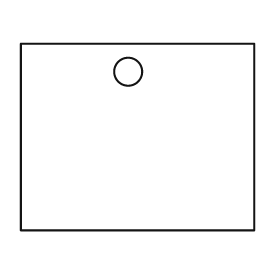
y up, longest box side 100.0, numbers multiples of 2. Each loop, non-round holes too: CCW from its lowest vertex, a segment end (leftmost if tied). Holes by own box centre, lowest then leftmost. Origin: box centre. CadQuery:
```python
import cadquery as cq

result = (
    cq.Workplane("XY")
    .moveTo(-50.0, -40.0)
    .lineTo(50.0, -40.0)
    .lineTo(50.0, 40.0)
    .lineTo(-50.0, 40.0)
    .close()
    .moveTo(-4.0, 28.0)
    .circle(6.0)
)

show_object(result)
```